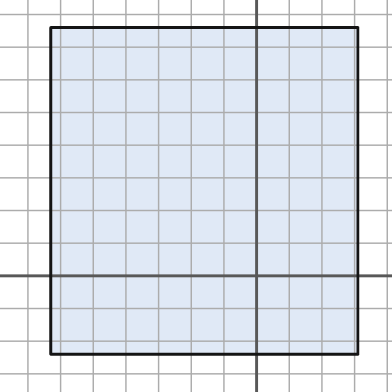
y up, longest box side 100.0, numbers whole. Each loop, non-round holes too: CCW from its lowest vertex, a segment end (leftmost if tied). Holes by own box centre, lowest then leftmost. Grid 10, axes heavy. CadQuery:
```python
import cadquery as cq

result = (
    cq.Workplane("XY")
    .moveTo(-63.0, -24.0)
    .lineTo(31.0, -24.0)
    .lineTo(31.0, 76.0)
    .lineTo(-63.0, 76.0)
    .close()
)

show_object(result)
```